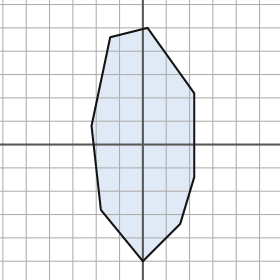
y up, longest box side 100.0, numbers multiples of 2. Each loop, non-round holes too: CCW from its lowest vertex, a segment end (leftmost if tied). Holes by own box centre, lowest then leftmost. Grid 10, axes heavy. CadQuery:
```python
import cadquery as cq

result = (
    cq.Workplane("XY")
    .moveTo(0.0, -50.0)
    .lineTo(16.0, -34.0)
    .lineTo(22.0, -14.0)
    .lineTo(22.0, 22.0)
    .lineTo(2.0, 50.0)
    .lineTo(-14.0, 46.0)
    .lineTo(-22.0, 8.0)
    .lineTo(-18.0, -28.0)
    .close()
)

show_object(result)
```